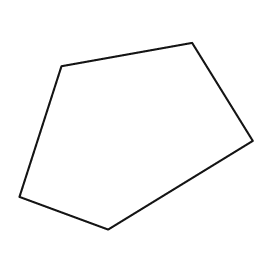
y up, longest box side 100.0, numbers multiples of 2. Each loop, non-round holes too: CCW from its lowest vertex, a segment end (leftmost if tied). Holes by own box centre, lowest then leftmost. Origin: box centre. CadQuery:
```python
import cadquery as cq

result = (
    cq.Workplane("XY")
    .moveTo(-12.0, -40.0)
    .lineTo(50.0, -2.0)
    .lineTo(24.0, 40.0)
    .lineTo(-32.0, 30.0)
    .lineTo(-50.0, -26.0)
    .close()
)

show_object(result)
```